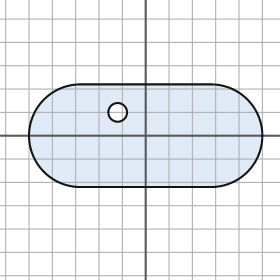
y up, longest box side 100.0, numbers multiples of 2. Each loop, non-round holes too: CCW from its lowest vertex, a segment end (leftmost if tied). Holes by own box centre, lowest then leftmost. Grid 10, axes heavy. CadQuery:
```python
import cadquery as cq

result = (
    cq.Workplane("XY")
    .moveTo(-28.0, -22.0)
    .lineTo(28.0, -22.0)
    .threePointArc((50.0, 0.0), (28.0, 22.0))
    .lineTo(-28.0, 22.0)
    .threePointArc((-50.0, 0.0), (-28.0, -22.0))
    .close()
    .moveTo(-12.0, 10.0)
    .circle(4.0)
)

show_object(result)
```